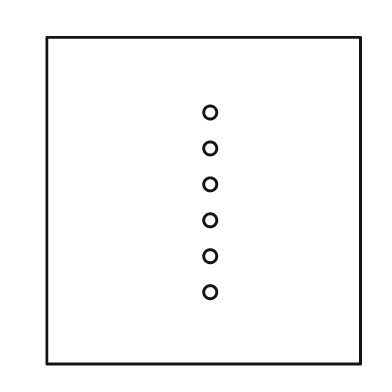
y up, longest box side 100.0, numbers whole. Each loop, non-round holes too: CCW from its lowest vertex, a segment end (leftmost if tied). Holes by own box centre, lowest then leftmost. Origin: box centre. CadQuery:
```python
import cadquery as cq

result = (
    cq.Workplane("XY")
    .moveTo(-48.0, -50.0)
    .lineTo(48.0, -50.0)
    .lineTo(48.0, 50.0)
    .lineTo(-48.0, 50.0)
    .close()
    .moveTo(2.0, -28.0)
    .circle(2.0)
    .moveTo(2.0, -17.0)
    .circle(2.0)
    .moveTo(2.0, -6.0)
    .circle(2.0)
    .moveTo(2.0, 5.0)
    .circle(2.0)
    .moveTo(2.0, 16.0)
    .circle(2.0)
    .moveTo(2.0, 27.0)
    .circle(2.0)
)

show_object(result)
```